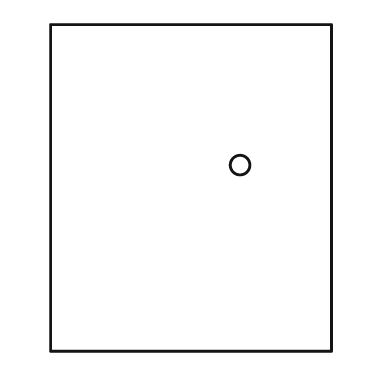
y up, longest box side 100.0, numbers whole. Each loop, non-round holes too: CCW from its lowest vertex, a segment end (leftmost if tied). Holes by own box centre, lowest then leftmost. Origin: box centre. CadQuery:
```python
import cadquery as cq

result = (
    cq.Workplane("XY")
    .moveTo(-43.0, -50.0)
    .lineTo(43.0, -50.0)
    .lineTo(43.0, 50.0)
    .lineTo(-43.0, 50.0)
    .close()
    .moveTo(15.0, 7.0)
    .circle(3.0)
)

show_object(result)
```